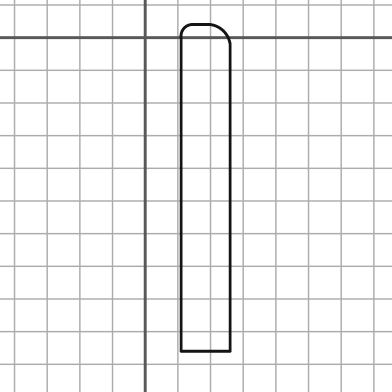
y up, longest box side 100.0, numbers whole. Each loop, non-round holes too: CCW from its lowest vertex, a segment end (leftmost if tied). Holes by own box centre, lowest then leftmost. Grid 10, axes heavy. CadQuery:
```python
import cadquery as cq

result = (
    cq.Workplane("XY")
    .moveTo(11.0, -96.0)
    .lineTo(26.0, -96.0)
    .lineTo(26.0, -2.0)
    .threePointArc((24.0, 2.0), (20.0, 4.0))
    .lineTo(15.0, 4.0)
    .threePointArc((12.0, 3.0), (11.0, 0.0))
    .close()
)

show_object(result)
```